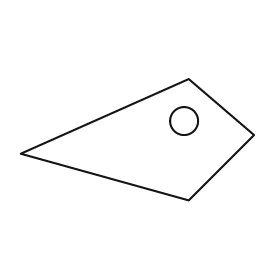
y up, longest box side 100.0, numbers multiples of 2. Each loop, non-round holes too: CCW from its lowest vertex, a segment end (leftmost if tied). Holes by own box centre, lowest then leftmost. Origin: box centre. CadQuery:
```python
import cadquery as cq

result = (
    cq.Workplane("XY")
    .moveTo(22.0, -26.0)
    .lineTo(50.0, 2.0)
    .lineTo(22.0, 26.0)
    .lineTo(-50.0, -6.0)
    .close()
    .moveTo(20.0, 8.0)
    .circle(6.0)
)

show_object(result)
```